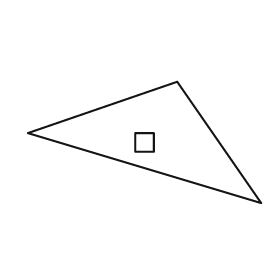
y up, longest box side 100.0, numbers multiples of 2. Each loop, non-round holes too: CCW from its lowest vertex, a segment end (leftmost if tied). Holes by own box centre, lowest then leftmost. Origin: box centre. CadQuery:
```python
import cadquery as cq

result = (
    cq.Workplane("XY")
    .moveTo(50.0, -26.0)
    .lineTo(14.0, 26.0)
    .lineTo(-50.0, 4.0)
    .close()
    .moveTo(-4.0, -4.0)
    .lineTo(4.0, -4.0)
    .lineTo(4.0, 4.0)
    .lineTo(-4.0, 4.0)
    .close()
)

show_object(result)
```